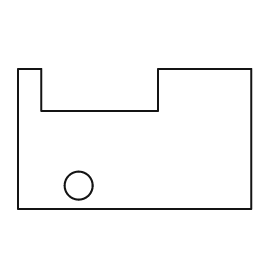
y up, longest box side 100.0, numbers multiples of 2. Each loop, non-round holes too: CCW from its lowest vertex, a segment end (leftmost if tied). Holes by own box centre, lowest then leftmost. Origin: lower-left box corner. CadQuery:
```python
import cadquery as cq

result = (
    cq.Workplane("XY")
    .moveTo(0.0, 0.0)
    .lineTo(100.0, 0.0)
    .lineTo(100.0, 60.0)
    .lineTo(60.0, 60.0)
    .lineTo(60.0, 42.0)
    .lineTo(10.0, 42.0)
    .lineTo(10.0, 60.0)
    .lineTo(0.0, 60.0)
    .close()
    .moveTo(26.0, 10.0)
    .circle(6.0)
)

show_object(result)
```